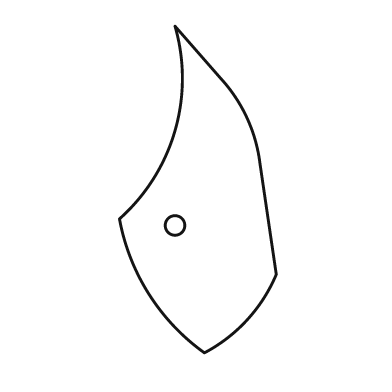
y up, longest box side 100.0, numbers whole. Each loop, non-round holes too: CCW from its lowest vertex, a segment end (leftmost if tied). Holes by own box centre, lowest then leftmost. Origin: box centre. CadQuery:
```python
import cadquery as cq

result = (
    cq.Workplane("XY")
    .moveTo(2.0, -50.0)
    .threePointArc((15.0, -40.0), (24.0, -26.0))
    .lineTo(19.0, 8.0)
    .threePointArc((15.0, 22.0), (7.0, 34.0))
    .lineTo(-7.0, 50.0)
    .threePointArc((-7.0, 18.0), (-24.0, -9.0))
    .threePointArc((-15.0, -32.0), (2.0, -50.0))
    .close()
    .moveTo(-7.0, -11.0)
    .circle(3.0)
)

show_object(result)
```